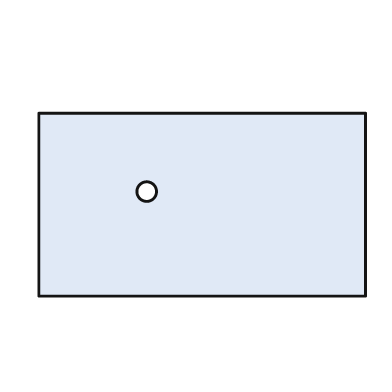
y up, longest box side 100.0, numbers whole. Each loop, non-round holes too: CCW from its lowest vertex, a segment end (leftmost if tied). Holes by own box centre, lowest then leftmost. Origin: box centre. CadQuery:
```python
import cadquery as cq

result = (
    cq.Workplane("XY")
    .moveTo(-50.0, -28.0)
    .lineTo(50.0, -28.0)
    .lineTo(50.0, 28.0)
    .lineTo(-50.0, 28.0)
    .close()
    .moveTo(-17.0, 4.0)
    .circle(3.0)
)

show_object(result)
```